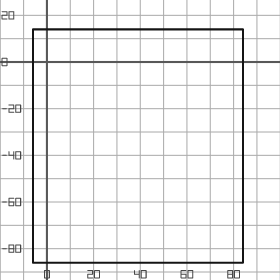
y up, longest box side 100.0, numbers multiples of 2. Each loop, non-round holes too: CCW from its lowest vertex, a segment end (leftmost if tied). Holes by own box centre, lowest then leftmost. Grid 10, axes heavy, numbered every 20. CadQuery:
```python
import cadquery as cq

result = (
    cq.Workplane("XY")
    .moveTo(-6.0, -86.0)
    .lineTo(84.0, -86.0)
    .lineTo(84.0, 14.0)
    .lineTo(-6.0, 14.0)
    .close()
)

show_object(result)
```